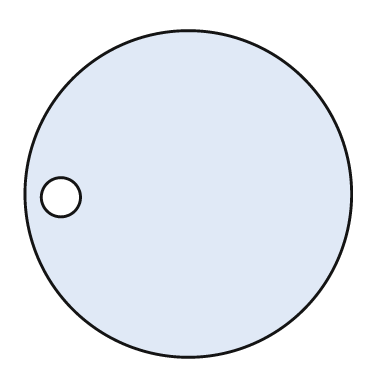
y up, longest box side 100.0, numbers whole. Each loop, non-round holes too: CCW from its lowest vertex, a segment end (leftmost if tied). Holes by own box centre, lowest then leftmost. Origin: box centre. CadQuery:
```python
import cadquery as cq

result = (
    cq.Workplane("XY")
    .moveTo(0.0, 0.0)
    .circle(50.0)
    .moveTo(-39.0, -1.0)
    .circle(6.0)
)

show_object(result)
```